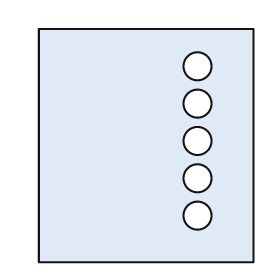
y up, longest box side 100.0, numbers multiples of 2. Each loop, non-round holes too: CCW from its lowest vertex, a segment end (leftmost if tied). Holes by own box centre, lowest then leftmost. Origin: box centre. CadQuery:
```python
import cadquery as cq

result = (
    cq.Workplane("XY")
    .moveTo(-46.0, -50.0)
    .lineTo(46.0, -50.0)
    .lineTo(46.0, 50.0)
    .lineTo(-46.0, 50.0)
    .close()
    .moveTo(22.0, -30.0)
    .circle(6.0)
    .moveTo(22.0, -14.0)
    .circle(6.0)
    .moveTo(22.0, 2.0)
    .circle(6.0)
    .moveTo(22.0, 18.0)
    .circle(6.0)
    .moveTo(22.0, 34.0)
    .circle(6.0)
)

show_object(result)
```